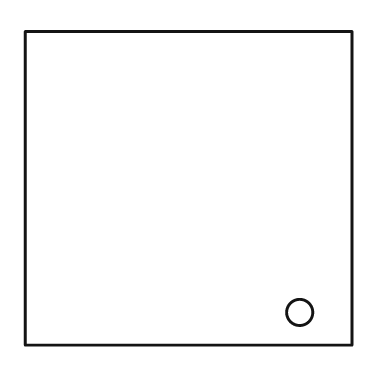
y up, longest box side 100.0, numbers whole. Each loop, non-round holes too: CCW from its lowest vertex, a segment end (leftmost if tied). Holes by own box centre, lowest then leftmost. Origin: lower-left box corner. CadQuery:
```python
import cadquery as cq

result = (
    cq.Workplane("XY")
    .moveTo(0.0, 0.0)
    .lineTo(100.0, 0.0)
    .lineTo(100.0, 96.0)
    .lineTo(0.0, 96.0)
    .close()
    .moveTo(84.0, 10.0)
    .circle(4.0)
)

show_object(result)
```